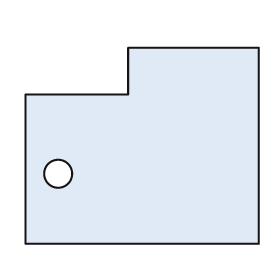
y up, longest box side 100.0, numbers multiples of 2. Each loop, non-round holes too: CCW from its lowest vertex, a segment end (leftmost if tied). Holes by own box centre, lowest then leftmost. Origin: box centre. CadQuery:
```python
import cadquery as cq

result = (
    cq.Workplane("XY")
    .moveTo(-50.0, -42.0)
    .lineTo(50.0, -42.0)
    .lineTo(50.0, 42.0)
    .lineTo(-6.0, 42.0)
    .lineTo(-6.0, 22.0)
    .lineTo(-50.0, 22.0)
    .close()
    .moveTo(-36.0, -12.0)
    .circle(6.0)
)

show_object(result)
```